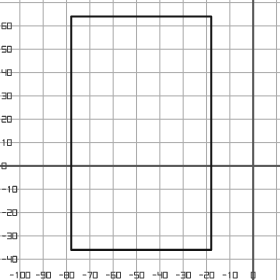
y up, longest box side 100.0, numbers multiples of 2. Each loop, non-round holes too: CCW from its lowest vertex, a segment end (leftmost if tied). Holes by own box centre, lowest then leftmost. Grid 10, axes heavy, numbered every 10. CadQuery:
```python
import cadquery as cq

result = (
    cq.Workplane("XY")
    .moveTo(-78.0, -36.0)
    .lineTo(-18.0, -36.0)
    .lineTo(-18.0, 64.0)
    .lineTo(-78.0, 64.0)
    .close()
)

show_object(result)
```